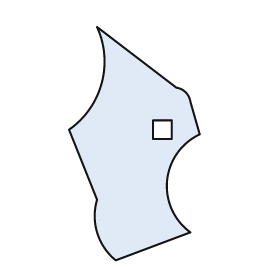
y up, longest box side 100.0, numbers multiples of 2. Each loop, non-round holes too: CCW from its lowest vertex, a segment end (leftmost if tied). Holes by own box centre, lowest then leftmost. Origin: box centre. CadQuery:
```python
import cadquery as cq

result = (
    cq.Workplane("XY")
    .moveTo(-8.0, -50.0)
    .lineTo(24.0, -38.0)
    .threePointArc((14.0, -16.0), (28.0, 4.0))
    .lineTo(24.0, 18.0)
    .threePointArc((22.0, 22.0), (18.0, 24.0))
    .lineTo(-16.0, 50.0)
    .threePointArc((-14.0, 26.0), (-28.0, 6.0))
    .lineTo(-16.0, -24.0)
    .threePointArc((-16.0, -38.0), (-8.0, -50.0))
    .close()
    .moveTo(8.0, 2.0)
    .lineTo(16.0, 2.0)
    .lineTo(16.0, 10.0)
    .lineTo(8.0, 10.0)
    .close()
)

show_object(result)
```